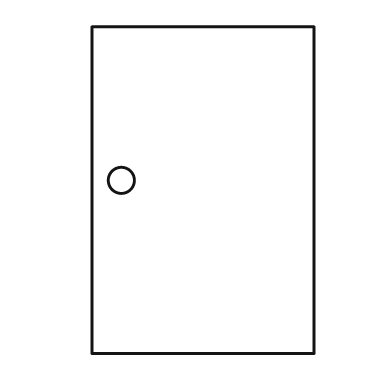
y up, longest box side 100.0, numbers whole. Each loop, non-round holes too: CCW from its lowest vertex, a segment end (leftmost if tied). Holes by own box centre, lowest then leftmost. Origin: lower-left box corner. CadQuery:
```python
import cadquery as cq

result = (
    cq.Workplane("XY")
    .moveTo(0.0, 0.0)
    .lineTo(68.0, 0.0)
    .lineTo(68.0, 100.0)
    .lineTo(0.0, 100.0)
    .close()
    .moveTo(9.0, 53.0)
    .circle(4.0)
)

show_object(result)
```